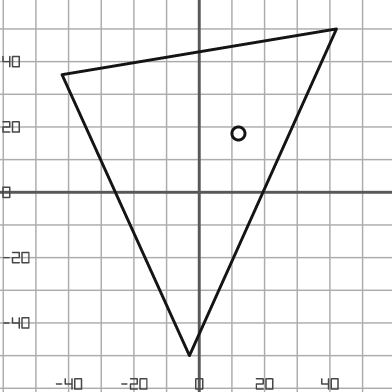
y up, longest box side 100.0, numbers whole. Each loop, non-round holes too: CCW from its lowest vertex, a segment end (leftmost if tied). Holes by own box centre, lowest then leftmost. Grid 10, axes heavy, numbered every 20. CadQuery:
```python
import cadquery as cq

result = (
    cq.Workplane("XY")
    .moveTo(-3.0, -50.0)
    .lineTo(42.0, 50.0)
    .lineTo(-42.0, 36.0)
    .close()
    .moveTo(12.0, 18.0)
    .circle(2.0)
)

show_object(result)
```